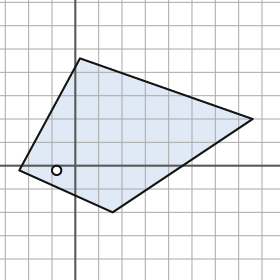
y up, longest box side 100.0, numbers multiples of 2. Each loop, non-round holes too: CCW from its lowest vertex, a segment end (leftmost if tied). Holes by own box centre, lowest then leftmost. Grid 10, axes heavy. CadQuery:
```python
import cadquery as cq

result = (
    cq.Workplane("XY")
    .moveTo(16.0, -20.0)
    .lineTo(76.0, 20.0)
    .lineTo(2.0, 46.0)
    .lineTo(-24.0, -2.0)
    .close()
    .moveTo(-8.0, -2.0)
    .circle(2.0)
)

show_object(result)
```